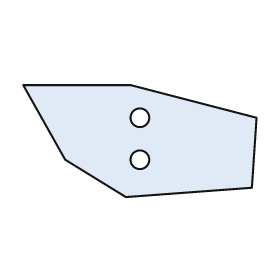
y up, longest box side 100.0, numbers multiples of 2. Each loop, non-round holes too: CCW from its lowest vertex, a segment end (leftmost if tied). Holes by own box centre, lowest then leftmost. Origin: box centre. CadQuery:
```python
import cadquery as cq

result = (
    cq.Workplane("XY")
    .moveTo(-6.0, -24.0)
    .lineTo(48.0, -20.0)
    .lineTo(50.0, 10.0)
    .lineTo(-4.0, 24.0)
    .lineTo(-50.0, 24.0)
    .lineTo(-32.0, -8.0)
    .close()
    .moveTo(0.0, -8.0)
    .circle(4.0)
    .moveTo(0.0, 10.0)
    .circle(4.0)
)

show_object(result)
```